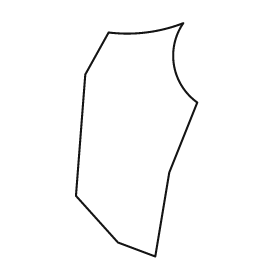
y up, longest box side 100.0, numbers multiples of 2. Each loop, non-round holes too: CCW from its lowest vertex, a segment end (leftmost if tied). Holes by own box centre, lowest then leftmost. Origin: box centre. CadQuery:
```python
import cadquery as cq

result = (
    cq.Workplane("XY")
    .moveTo(8.0, -50.0)
    .lineTo(14.0, -14.0)
    .lineTo(26.0, 16.0)
    .threePointArc((16.0, 32.0), (20.0, 50.0))
    .threePointArc((4.0, 46.0), (-12.0, 46.0))
    .lineTo(-22.0, 28.0)
    .lineTo(-26.0, -24.0)
    .lineTo(-8.0, -44.0)
    .close()
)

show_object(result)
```